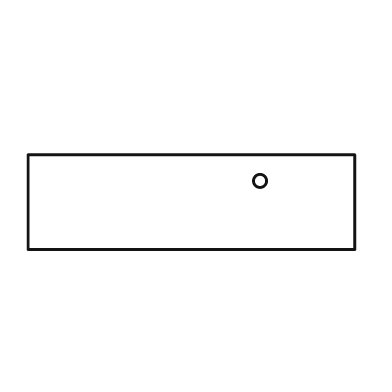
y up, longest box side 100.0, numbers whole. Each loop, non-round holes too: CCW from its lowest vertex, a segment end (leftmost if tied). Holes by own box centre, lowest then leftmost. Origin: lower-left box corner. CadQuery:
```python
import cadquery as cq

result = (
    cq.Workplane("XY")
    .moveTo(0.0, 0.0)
    .lineTo(100.0, 0.0)
    .lineTo(100.0, 29.0)
    .lineTo(0.0, 29.0)
    .close()
    .moveTo(71.0, 21.0)
    .circle(2.0)
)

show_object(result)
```